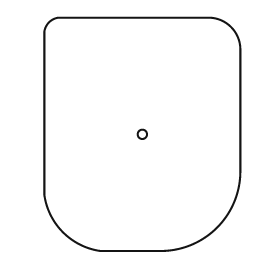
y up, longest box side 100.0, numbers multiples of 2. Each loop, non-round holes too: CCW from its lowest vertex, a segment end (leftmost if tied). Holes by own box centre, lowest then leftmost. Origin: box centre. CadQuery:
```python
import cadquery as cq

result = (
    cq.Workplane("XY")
    .moveTo(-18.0, -50.0)
    .lineTo(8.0, -50.0)
    .threePointArc((32.0, -40.0), (42.0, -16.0))
    .lineTo(42.0, 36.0)
    .threePointArc((38.0, 46.0), (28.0, 50.0))
    .lineTo(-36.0, 50.0)
    .threePointArc((-40.0, 48.0), (-42.0, 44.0))
    .lineTo(-42.0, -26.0)
    .threePointArc((-34.0, -42.0), (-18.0, -50.0))
    .close()
    .moveTo(0.0, 0.0)
    .circle(2.0)
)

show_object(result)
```